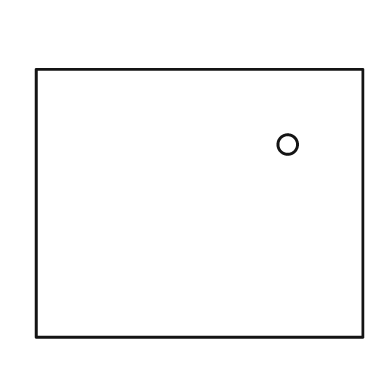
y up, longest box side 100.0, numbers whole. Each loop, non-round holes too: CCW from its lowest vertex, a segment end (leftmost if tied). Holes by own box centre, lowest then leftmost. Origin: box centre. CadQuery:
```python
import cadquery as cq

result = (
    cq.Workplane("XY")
    .moveTo(-50.0, -41.0)
    .lineTo(50.0, -41.0)
    .lineTo(50.0, 41.0)
    .lineTo(-50.0, 41.0)
    .close()
    .moveTo(27.0, 18.0)
    .circle(3.0)
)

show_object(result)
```